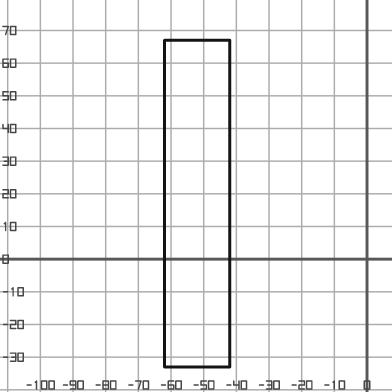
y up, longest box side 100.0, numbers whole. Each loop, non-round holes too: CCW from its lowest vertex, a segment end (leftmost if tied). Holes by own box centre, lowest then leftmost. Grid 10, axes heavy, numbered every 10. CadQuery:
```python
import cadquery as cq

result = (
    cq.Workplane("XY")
    .moveTo(-62.0, -33.0)
    .lineTo(-42.0, -33.0)
    .lineTo(-42.0, 67.0)
    .lineTo(-62.0, 67.0)
    .close()
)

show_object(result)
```